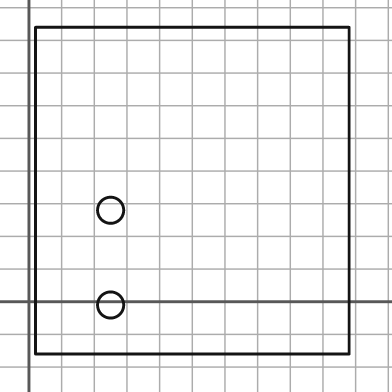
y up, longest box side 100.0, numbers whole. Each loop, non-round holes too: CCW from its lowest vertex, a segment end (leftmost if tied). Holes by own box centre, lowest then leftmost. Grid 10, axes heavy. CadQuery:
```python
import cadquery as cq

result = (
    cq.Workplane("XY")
    .moveTo(2.0, -16.0)
    .lineTo(98.0, -16.0)
    .lineTo(98.0, 84.0)
    .lineTo(2.0, 84.0)
    .close()
    .moveTo(25.0, -1.0)
    .circle(4.0)
    .moveTo(25.0, 28.0)
    .circle(4.0)
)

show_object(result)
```